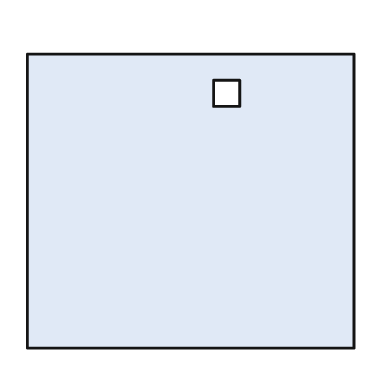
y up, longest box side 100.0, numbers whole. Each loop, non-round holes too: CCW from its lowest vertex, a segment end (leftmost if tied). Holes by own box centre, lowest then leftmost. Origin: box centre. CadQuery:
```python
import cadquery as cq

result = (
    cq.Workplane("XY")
    .moveTo(-50.0, -45.0)
    .lineTo(50.0, -45.0)
    .lineTo(50.0, 45.0)
    .lineTo(-50.0, 45.0)
    .close()
    .moveTo(7.0, 29.0)
    .lineTo(15.0, 29.0)
    .lineTo(15.0, 37.0)
    .lineTo(7.0, 37.0)
    .close()
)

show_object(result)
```